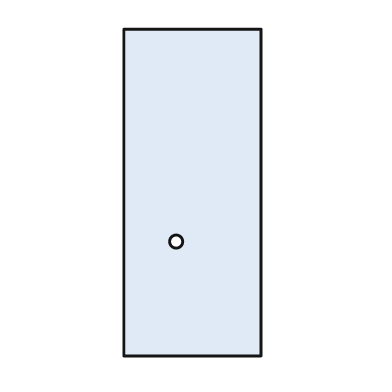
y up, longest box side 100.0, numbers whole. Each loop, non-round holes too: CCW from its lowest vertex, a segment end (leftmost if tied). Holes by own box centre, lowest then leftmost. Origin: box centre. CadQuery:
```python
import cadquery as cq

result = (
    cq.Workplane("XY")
    .moveTo(-21.0, -50.0)
    .lineTo(21.0, -50.0)
    .lineTo(21.0, 50.0)
    .lineTo(-21.0, 50.0)
    .close()
    .moveTo(-5.0, -15.0)
    .circle(2.0)
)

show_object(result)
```